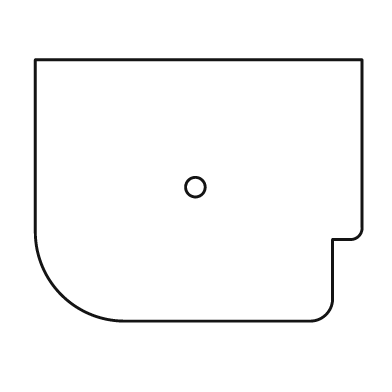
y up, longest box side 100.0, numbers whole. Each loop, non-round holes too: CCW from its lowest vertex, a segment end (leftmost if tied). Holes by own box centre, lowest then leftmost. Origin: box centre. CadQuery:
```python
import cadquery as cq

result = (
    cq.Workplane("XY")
    .moveTo(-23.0, -40.0)
    .lineTo(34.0, -40.0)
    .threePointArc((39.0, -38.0), (41.0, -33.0))
    .lineTo(41.0, -15.0)
    .lineTo(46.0, -15.0)
    .threePointArc((49.0, -14.0), (50.0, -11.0))
    .lineTo(50.0, 40.0)
    .lineTo(-50.0, 40.0)
    .lineTo(-50.0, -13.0)
    .threePointArc((-42.0, -32.0), (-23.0, -40.0))
    .close()
    .moveTo(-1.0, 1.0)
    .circle(3.0)
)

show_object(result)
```